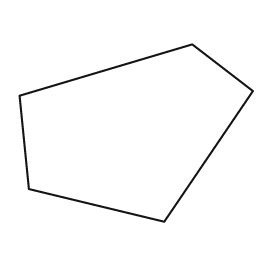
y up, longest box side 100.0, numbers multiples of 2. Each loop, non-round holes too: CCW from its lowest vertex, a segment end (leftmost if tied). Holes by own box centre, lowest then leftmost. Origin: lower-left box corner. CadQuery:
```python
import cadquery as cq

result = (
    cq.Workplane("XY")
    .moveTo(62.0, 0.0)
    .lineTo(100.0, 56.0)
    .lineTo(74.0, 76.0)
    .lineTo(0.0, 54.0)
    .lineTo(4.0, 14.0)
    .close()
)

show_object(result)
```